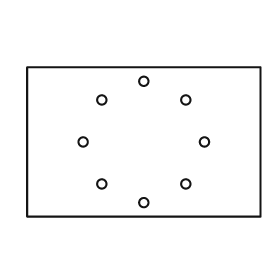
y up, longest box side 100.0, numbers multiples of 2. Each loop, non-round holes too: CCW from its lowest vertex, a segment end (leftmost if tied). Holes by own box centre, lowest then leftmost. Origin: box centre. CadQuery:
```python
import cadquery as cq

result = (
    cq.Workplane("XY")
    .moveTo(-50.0, -32.0)
    .lineTo(50.0, -32.0)
    .lineTo(50.0, 32.0)
    .lineTo(-50.0, 32.0)
    .close()
    .moveTo(0.0, -26.0)
    .circle(2.0)
    .moveTo(-18.0, -18.0)
    .circle(2.0)
    .moveTo(18.0, -18.0)
    .circle(2.0)
    .moveTo(-26.0, 0.0)
    .circle(2.0)
    .moveTo(26.0, 0.0)
    .circle(2.0)
    .moveTo(-18.0, 18.0)
    .circle(2.0)
    .moveTo(18.0, 18.0)
    .circle(2.0)
    .moveTo(0.0, 26.0)
    .circle(2.0)
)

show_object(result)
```